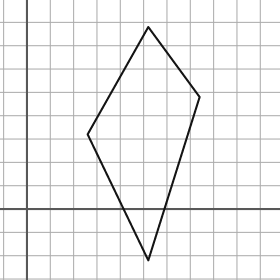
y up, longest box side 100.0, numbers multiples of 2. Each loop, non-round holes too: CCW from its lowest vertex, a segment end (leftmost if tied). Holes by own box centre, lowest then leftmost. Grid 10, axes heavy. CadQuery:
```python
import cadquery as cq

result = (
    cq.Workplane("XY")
    .moveTo(52.0, -22.0)
    .lineTo(74.0, 48.0)
    .lineTo(52.0, 78.0)
    .lineTo(26.0, 32.0)
    .close()
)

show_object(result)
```